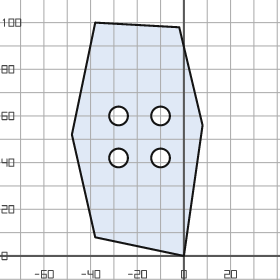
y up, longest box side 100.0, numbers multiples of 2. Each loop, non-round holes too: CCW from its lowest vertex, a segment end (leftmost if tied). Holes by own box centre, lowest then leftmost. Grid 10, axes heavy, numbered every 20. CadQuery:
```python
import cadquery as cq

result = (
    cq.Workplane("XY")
    .moveTo(0.0, 0.0)
    .lineTo(8.0, 56.0)
    .lineTo(-2.0, 98.0)
    .lineTo(-38.0, 100.0)
    .lineTo(-48.0, 52.0)
    .lineTo(-38.0, 8.0)
    .close()
    .moveTo(-28.0, 42.0)
    .circle(4.0)
    .moveTo(-10.0, 42.0)
    .circle(4.0)
    .moveTo(-28.0, 60.0)
    .circle(4.0)
    .moveTo(-10.0, 60.0)
    .circle(4.0)
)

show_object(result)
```